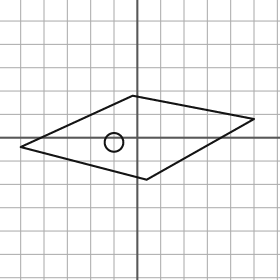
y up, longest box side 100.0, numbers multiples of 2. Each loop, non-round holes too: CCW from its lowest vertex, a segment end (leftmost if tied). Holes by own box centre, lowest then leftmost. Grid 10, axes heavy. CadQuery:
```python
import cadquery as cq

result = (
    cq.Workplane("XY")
    .moveTo(4.0, -18.0)
    .lineTo(50.0, 8.0)
    .lineTo(-2.0, 18.0)
    .lineTo(-50.0, -4.0)
    .close()
    .moveTo(-10.0, -2.0)
    .circle(4.0)
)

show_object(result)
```